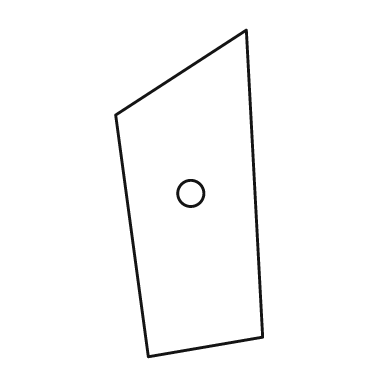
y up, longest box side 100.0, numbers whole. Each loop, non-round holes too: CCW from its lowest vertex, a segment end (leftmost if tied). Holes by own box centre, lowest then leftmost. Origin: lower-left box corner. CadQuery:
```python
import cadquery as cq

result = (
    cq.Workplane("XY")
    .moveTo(10.0, 0.0)
    .lineTo(45.0, 6.0)
    .lineTo(40.0, 100.0)
    .lineTo(0.0, 74.0)
    .close()
    .moveTo(23.0, 50.0)
    .circle(4.0)
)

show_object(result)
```